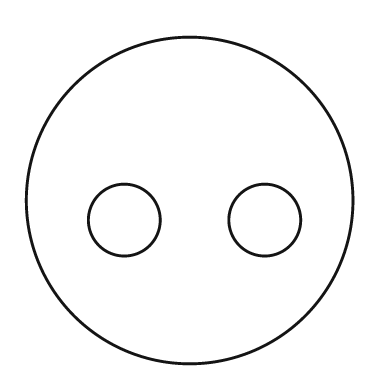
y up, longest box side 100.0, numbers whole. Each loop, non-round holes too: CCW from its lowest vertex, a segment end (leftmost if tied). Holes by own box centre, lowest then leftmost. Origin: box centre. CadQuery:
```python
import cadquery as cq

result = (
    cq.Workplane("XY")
    .moveTo(0.0, 0.0)
    .circle(50.0)
    .moveTo(-20.0, -6.0)
    .circle(11.0)
    .moveTo(23.0, -6.0)
    .circle(11.0)
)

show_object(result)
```